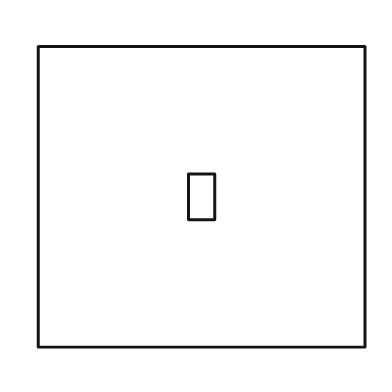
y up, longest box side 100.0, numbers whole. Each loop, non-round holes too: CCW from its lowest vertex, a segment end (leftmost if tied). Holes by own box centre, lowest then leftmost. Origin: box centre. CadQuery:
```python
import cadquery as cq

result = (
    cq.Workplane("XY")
    .moveTo(-50.0, -46.0)
    .lineTo(50.0, -46.0)
    .lineTo(50.0, 46.0)
    .lineTo(-50.0, 46.0)
    .close()
    .moveTo(-4.0, -7.0)
    .lineTo(4.0, -7.0)
    .lineTo(4.0, 7.0)
    .lineTo(-4.0, 7.0)
    .close()
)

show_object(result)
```